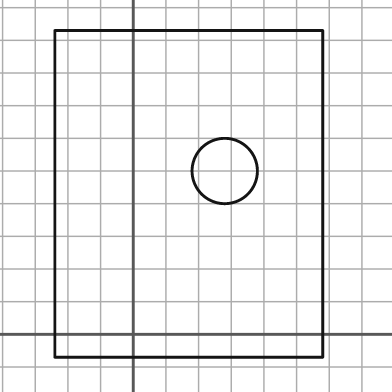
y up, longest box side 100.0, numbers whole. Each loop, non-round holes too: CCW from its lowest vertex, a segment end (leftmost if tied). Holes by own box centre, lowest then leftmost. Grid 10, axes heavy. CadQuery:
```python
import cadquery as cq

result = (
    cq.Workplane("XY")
    .moveTo(-24.0, -7.0)
    .lineTo(58.0, -7.0)
    .lineTo(58.0, 93.0)
    .lineTo(-24.0, 93.0)
    .close()
    .moveTo(28.0, 50.0)
    .circle(10.0)
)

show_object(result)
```